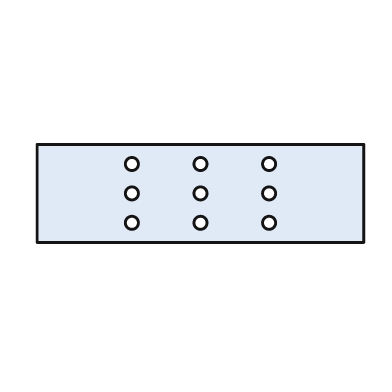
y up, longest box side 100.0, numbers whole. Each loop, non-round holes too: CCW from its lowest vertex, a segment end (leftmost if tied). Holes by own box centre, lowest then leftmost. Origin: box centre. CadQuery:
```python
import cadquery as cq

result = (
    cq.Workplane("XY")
    .moveTo(-50.0, -15.0)
    .lineTo(50.0, -15.0)
    .lineTo(50.0, 15.0)
    .lineTo(-50.0, 15.0)
    .close()
    .moveTo(-21.0, -9.0)
    .circle(2.0)
    .moveTo(0.0, -9.0)
    .circle(2.0)
    .moveTo(21.0, -9.0)
    .circle(2.0)
    .moveTo(-21.0, 0.0)
    .circle(2.0)
    .moveTo(0.0, 0.0)
    .circle(2.0)
    .moveTo(21.0, 0.0)
    .circle(2.0)
    .moveTo(-21.0, 9.0)
    .circle(2.0)
    .moveTo(0.0, 9.0)
    .circle(2.0)
    .moveTo(21.0, 9.0)
    .circle(2.0)
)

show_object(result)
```